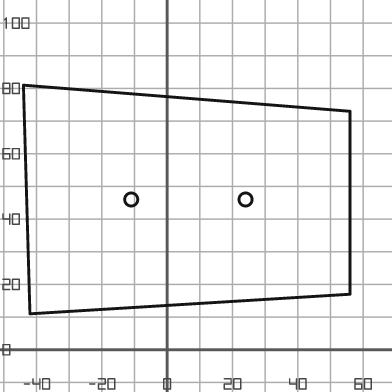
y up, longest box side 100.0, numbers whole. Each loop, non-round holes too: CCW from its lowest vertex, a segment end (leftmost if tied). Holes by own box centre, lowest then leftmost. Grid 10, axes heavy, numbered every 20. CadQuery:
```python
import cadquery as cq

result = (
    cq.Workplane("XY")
    .moveTo(-42.0, 11.0)
    .lineTo(56.0, 17.0)
    .lineTo(56.0, 73.0)
    .lineTo(-44.0, 81.0)
    .close()
    .moveTo(-11.0, 46.0)
    .circle(2.0)
    .moveTo(24.0, 46.0)
    .circle(2.0)
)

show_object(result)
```